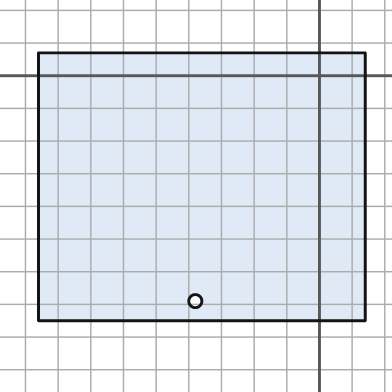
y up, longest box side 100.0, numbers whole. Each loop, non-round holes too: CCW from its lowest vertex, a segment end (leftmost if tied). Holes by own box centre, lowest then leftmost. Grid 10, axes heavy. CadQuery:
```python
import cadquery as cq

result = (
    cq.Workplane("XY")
    .moveTo(-86.0, -75.0)
    .lineTo(14.0, -75.0)
    .lineTo(14.0, 7.0)
    .lineTo(-86.0, 7.0)
    .close()
    .moveTo(-38.0, -69.0)
    .circle(2.0)
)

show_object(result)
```